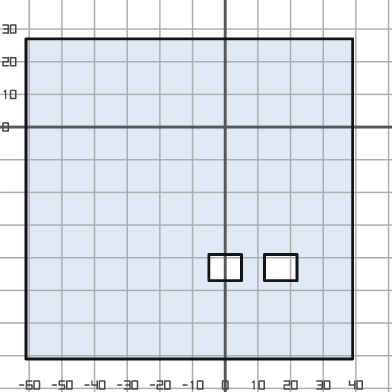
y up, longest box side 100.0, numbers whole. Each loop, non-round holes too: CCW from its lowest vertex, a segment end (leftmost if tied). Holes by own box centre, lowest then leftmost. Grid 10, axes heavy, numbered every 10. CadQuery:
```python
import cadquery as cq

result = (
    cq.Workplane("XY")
    .moveTo(-61.0, -71.0)
    .lineTo(39.0, -71.0)
    .lineTo(39.0, 27.0)
    .lineTo(-61.0, 27.0)
    .close()
    .moveTo(-5.0, -47.0)
    .lineTo(5.0, -47.0)
    .lineTo(5.0, -39.0)
    .lineTo(-5.0, -39.0)
    .close()
    .moveTo(12.0, -47.0)
    .lineTo(22.0, -47.0)
    .lineTo(22.0, -39.0)
    .lineTo(12.0, -39.0)
    .close()
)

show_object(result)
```